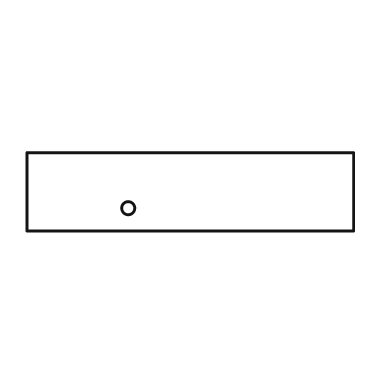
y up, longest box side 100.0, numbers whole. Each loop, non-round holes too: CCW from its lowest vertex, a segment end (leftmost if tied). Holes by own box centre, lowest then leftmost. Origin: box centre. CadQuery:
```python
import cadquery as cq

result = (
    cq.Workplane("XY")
    .moveTo(-50.0, -12.0)
    .lineTo(50.0, -12.0)
    .lineTo(50.0, 12.0)
    .lineTo(-50.0, 12.0)
    .close()
    .moveTo(-19.0, -5.0)
    .circle(2.0)
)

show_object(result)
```